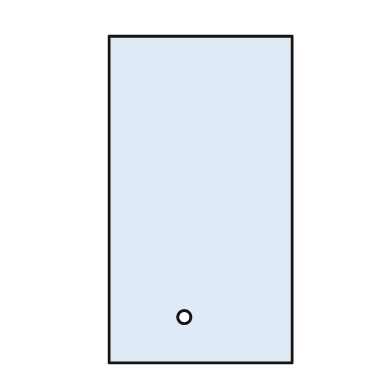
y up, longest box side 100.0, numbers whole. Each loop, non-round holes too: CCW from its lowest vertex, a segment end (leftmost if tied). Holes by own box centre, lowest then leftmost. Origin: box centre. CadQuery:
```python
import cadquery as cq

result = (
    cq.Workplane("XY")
    .moveTo(-28.0, -50.0)
    .lineTo(28.0, -50.0)
    .lineTo(28.0, 50.0)
    .lineTo(-28.0, 50.0)
    .close()
    .moveTo(-5.0, -36.0)
    .circle(2.0)
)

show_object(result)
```